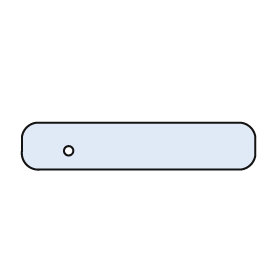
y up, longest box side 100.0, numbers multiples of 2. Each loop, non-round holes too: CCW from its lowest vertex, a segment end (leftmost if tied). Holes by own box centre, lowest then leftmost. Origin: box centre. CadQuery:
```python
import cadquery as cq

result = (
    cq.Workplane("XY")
    .moveTo(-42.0, -10.0)
    .lineTo(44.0, -10.0)
    .threePointArc((48.0, -8.0), (50.0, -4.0))
    .lineTo(50.0, 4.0)
    .threePointArc((48.0, 8.0), (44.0, 10.0))
    .lineTo(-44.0, 10.0)
    .threePointArc((-48.0, 8.0), (-50.0, 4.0))
    .lineTo(-50.0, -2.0)
    .threePointArc((-48.0, -8.0), (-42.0, -10.0))
    .close()
    .moveTo(-30.0, -2.0)
    .circle(2.0)
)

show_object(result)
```